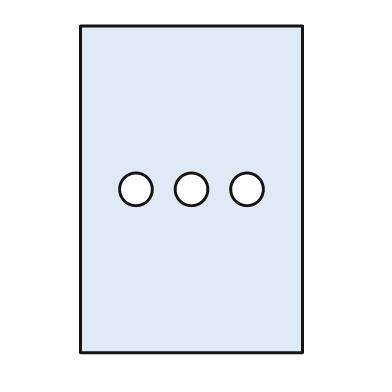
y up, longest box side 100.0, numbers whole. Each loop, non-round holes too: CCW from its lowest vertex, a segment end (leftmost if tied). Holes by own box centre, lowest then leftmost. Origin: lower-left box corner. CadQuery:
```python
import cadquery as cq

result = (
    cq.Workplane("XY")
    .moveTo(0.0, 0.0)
    .lineTo(68.0, 0.0)
    .lineTo(68.0, 100.0)
    .lineTo(0.0, 100.0)
    .close()
    .moveTo(17.0, 50.0)
    .circle(5.0)
    .moveTo(34.0, 50.0)
    .circle(5.0)
    .moveTo(51.0, 50.0)
    .circle(5.0)
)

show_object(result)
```